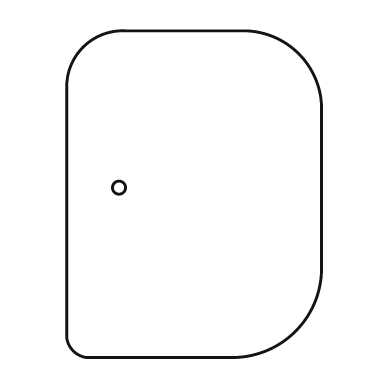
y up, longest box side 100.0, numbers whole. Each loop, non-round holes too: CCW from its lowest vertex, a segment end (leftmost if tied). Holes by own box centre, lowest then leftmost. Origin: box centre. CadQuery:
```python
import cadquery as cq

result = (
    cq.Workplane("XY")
    .moveTo(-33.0, -50.0)
    .lineTo(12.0, -50.0)
    .threePointArc((31.0, -42.0), (39.0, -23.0))
    .lineTo(39.0, 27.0)
    .threePointArc((32.0, 43.0), (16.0, 50.0))
    .lineTo(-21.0, 50.0)
    .threePointArc((-34.0, 45.0), (-39.0, 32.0))
    .lineTo(-39.0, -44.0)
    .threePointArc((-37.0, -48.0), (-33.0, -50.0))
    .close()
    .moveTo(-23.0, 2.0)
    .circle(2.0)
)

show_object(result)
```